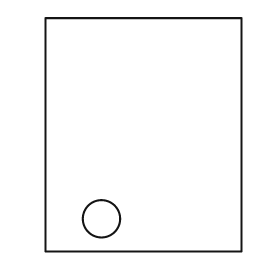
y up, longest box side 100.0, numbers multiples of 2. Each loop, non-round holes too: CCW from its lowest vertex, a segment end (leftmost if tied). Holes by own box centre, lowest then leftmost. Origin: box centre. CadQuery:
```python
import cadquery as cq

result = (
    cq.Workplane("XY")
    .moveTo(-42.0, -50.0)
    .lineTo(42.0, -50.0)
    .lineTo(42.0, 50.0)
    .lineTo(-42.0, 50.0)
    .close()
    .moveTo(-18.0, -36.0)
    .circle(8.0)
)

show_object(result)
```